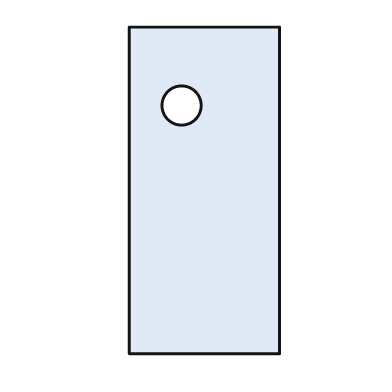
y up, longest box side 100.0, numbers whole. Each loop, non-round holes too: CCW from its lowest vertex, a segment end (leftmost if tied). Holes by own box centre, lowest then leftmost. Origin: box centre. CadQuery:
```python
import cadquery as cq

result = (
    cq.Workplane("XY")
    .moveTo(-23.0, -50.0)
    .lineTo(23.0, -50.0)
    .lineTo(23.0, 50.0)
    .lineTo(-23.0, 50.0)
    .close()
    .moveTo(-7.0, 26.0)
    .circle(6.0)
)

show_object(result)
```